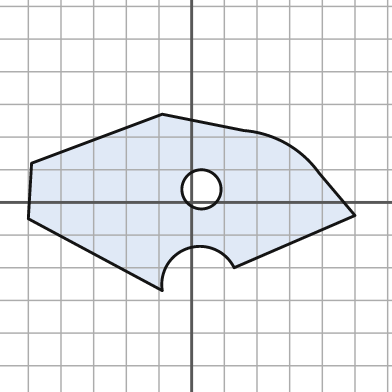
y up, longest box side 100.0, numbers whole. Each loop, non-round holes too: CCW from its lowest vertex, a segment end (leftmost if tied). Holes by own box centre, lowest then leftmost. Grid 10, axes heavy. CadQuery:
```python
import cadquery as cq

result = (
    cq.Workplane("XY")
    .moveTo(-9.0, -27.0)
    .threePointArc((-1.0, -14.0), (13.0, -20.0))
    .lineTo(50.0, -4.0)
    .lineTo(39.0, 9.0)
    .threePointArc((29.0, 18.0), (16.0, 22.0))
    .lineTo(-9.0, 27.0)
    .lineTo(-49.0, 12.0)
    .lineTo(-50.0, -5.0)
    .close()
    .moveTo(3.0, 4.0)
    .circle(6.0)
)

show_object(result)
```